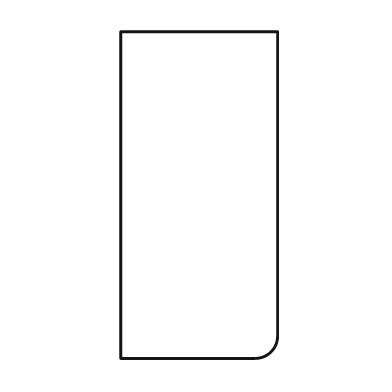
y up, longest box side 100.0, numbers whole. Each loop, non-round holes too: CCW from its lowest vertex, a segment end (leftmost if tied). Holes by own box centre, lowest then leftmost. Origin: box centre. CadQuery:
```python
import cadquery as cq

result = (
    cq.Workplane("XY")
    .moveTo(-24.0, -50.0)
    .lineTo(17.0, -50.0)
    .threePointArc((22.0, -48.0), (24.0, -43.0))
    .lineTo(24.0, 50.0)
    .lineTo(-24.0, 50.0)
    .close()
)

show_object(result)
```